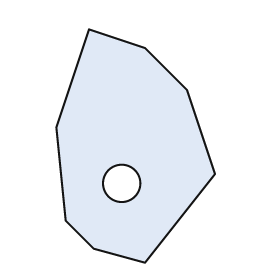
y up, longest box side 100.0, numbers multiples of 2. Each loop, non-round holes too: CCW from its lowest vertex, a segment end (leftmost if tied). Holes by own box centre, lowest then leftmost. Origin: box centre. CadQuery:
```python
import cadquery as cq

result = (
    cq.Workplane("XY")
    .moveTo(4.0, -50.0)
    .lineTo(34.0, -12.0)
    .lineTo(22.0, 24.0)
    .lineTo(4.0, 42.0)
    .lineTo(-20.0, 50.0)
    .lineTo(-34.0, 8.0)
    .lineTo(-30.0, -32.0)
    .lineTo(-18.0, -44.0)
    .close()
    .moveTo(-6.0, -16.0)
    .circle(8.0)
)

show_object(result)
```